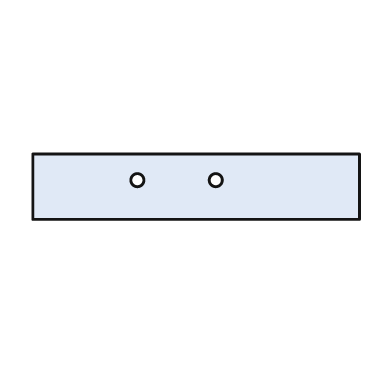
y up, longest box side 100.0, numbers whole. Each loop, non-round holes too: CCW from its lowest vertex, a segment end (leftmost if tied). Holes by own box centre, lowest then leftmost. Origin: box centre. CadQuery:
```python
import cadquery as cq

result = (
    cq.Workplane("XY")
    .moveTo(-50.0, -10.0)
    .lineTo(50.0, -10.0)
    .lineTo(50.0, 10.0)
    .lineTo(-50.0, 10.0)
    .close()
    .moveTo(-18.0, 2.0)
    .circle(2.0)
    .moveTo(6.0, 2.0)
    .circle(2.0)
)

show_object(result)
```